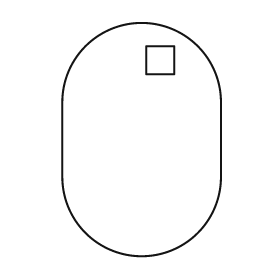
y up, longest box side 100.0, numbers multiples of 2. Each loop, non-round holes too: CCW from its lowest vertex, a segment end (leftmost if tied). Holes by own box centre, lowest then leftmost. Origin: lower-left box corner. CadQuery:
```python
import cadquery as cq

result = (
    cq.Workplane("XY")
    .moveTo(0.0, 34.0)
    .threePointArc((34.0, 0.0), (68.0, 34.0))
    .lineTo(68.0, 66.0)
    .threePointArc((34.0, 100.0), (0.0, 66.0))
    .close()
    .moveTo(36.0, 78.0)
    .lineTo(48.0, 78.0)
    .lineTo(48.0, 90.0)
    .lineTo(36.0, 90.0)
    .close()
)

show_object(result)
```